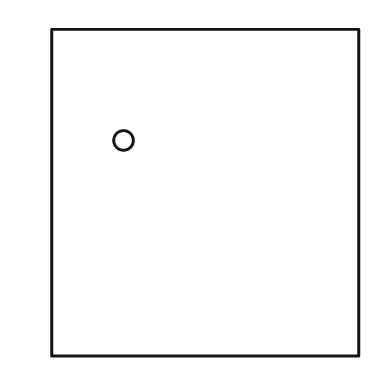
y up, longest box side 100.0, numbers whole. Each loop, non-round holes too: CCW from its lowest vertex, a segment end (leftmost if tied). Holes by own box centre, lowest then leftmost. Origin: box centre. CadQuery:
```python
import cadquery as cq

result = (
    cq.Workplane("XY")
    .moveTo(-47.0, -50.0)
    .lineTo(47.0, -50.0)
    .lineTo(47.0, 50.0)
    .lineTo(-47.0, 50.0)
    .close()
    .moveTo(-25.0, 16.0)
    .circle(3.0)
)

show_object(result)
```